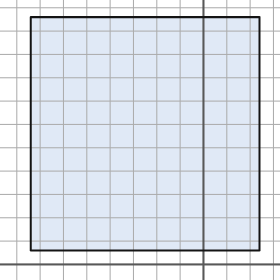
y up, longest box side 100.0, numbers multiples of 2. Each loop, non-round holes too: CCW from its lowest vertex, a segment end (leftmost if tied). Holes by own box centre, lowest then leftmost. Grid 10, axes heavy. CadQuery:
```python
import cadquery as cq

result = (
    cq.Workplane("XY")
    .moveTo(-74.0, 6.0)
    .lineTo(24.0, 6.0)
    .lineTo(24.0, 106.0)
    .lineTo(-74.0, 106.0)
    .close()
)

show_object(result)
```